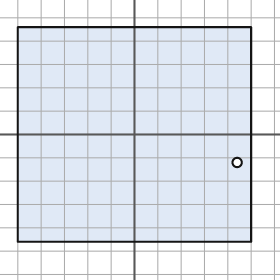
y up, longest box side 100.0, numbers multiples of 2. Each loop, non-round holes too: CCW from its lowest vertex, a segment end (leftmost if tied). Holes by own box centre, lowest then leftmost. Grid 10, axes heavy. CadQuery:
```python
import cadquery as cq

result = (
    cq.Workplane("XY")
    .moveTo(-50.0, -46.0)
    .lineTo(50.0, -46.0)
    .lineTo(50.0, 46.0)
    .lineTo(-50.0, 46.0)
    .close()
    .moveTo(44.0, -12.0)
    .circle(2.0)
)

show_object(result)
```